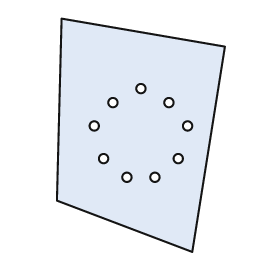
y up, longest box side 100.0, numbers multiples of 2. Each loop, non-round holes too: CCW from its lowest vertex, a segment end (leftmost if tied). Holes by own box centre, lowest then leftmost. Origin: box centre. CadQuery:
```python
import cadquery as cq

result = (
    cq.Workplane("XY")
    .moveTo(22.0, -50.0)
    .lineTo(36.0, 38.0)
    .lineTo(-34.0, 50.0)
    .lineTo(-36.0, -28.0)
    .close()
    .moveTo(-6.0, -18.0)
    .circle(2.0)
    .moveTo(6.0, -18.0)
    .circle(2.0)
    .moveTo(-16.0, -10.0)
    .circle(2.0)
    .moveTo(16.0, -10.0)
    .circle(2.0)
    .moveTo(-20.0, 4.0)
    .circle(2.0)
    .moveTo(20.0, 4.0)
    .circle(2.0)
    .moveTo(-12.0, 14.0)
    .circle(2.0)
    .moveTo(12.0, 14.0)
    .circle(2.0)
    .moveTo(0.0, 20.0)
    .circle(2.0)
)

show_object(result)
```